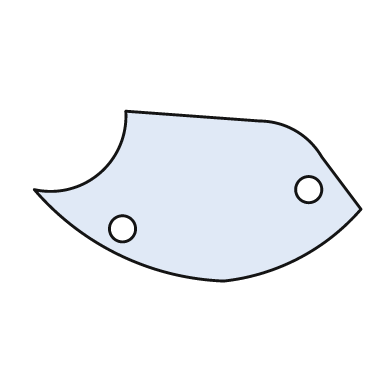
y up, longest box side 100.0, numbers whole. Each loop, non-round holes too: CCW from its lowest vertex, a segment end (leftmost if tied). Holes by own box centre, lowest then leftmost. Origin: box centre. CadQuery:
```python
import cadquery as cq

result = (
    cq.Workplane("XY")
    .moveTo(8.0, -26.0)
    .threePointArc((31.0, -19.0), (50.0, -4.0))
    .lineTo(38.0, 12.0)
    .threePointArc((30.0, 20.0), (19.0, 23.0))
    .lineTo(-22.0, 26.0)
    .threePointArc((-30.0, 7.0), (-50.0, 2.0))
    .threePointArc((-24.0, -18.0), (8.0, -26.0))
    .close()
    .moveTo(-23.0, -10.0)
    .circle(4.0)
    .moveTo(34.0, 2.0)
    .circle(4.0)
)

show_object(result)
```